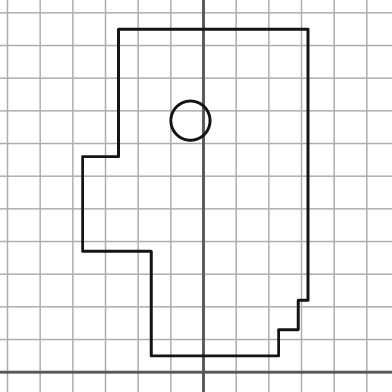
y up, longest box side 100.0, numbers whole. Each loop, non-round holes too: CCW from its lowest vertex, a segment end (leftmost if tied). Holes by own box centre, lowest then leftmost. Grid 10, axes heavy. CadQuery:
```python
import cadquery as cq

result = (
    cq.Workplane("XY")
    .moveTo(-16.0, 5.0)
    .lineTo(23.0, 5.0)
    .lineTo(23.0, 13.0)
    .lineTo(29.0, 13.0)
    .lineTo(29.0, 22.0)
    .lineTo(32.0, 22.0)
    .lineTo(32.0, 105.0)
    .lineTo(-26.0, 105.0)
    .lineTo(-26.0, 66.0)
    .lineTo(-37.0, 66.0)
    .lineTo(-37.0, 37.0)
    .lineTo(-16.0, 37.0)
    .close()
    .moveTo(-4.0, 77.0)
    .circle(6.0)
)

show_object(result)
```